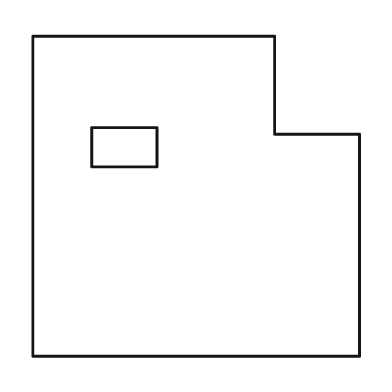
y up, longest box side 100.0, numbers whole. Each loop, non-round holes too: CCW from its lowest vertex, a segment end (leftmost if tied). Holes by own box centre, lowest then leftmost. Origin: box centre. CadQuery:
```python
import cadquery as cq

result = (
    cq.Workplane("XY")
    .moveTo(-50.0, -49.0)
    .lineTo(50.0, -49.0)
    .lineTo(50.0, 19.0)
    .lineTo(24.0, 19.0)
    .lineTo(24.0, 49.0)
    .lineTo(-50.0, 49.0)
    .close()
    .moveTo(-32.0, 9.0)
    .lineTo(-12.0, 9.0)
    .lineTo(-12.0, 21.0)
    .lineTo(-32.0, 21.0)
    .close()
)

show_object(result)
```